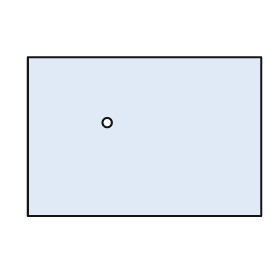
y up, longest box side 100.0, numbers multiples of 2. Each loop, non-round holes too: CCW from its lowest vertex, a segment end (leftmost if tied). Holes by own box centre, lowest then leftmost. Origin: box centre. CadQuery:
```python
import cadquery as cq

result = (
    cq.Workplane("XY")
    .moveTo(-50.0, -34.0)
    .lineTo(50.0, -34.0)
    .lineTo(50.0, 34.0)
    .lineTo(-50.0, 34.0)
    .close()
    .moveTo(-16.0, 6.0)
    .circle(2.0)
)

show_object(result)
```